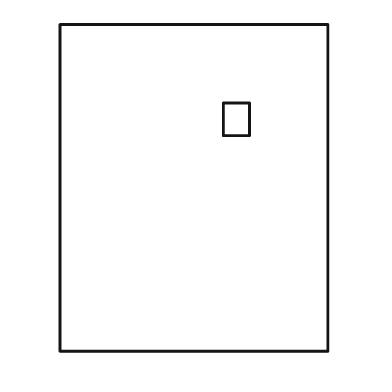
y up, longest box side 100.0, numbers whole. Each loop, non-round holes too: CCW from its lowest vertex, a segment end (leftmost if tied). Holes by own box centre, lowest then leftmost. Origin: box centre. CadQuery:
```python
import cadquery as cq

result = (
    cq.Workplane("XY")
    .moveTo(-41.0, -50.0)
    .lineTo(41.0, -50.0)
    .lineTo(41.0, 50.0)
    .lineTo(-41.0, 50.0)
    .close()
    .moveTo(9.0, 16.0)
    .lineTo(17.0, 16.0)
    .lineTo(17.0, 26.0)
    .lineTo(9.0, 26.0)
    .close()
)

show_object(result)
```